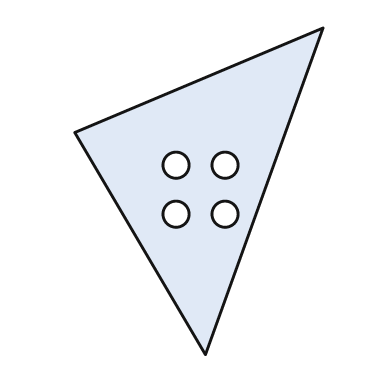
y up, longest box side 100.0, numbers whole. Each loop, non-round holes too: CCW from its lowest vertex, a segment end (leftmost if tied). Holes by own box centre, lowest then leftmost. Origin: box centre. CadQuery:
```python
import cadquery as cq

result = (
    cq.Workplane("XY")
    .moveTo(2.0, -50.0)
    .lineTo(38.0, 50.0)
    .lineTo(-38.0, 18.0)
    .close()
    .moveTo(-7.0, -7.0)
    .circle(4.0)
    .moveTo(8.0, -7.0)
    .circle(4.0)
    .moveTo(-7.0, 8.0)
    .circle(4.0)
    .moveTo(8.0, 8.0)
    .circle(4.0)
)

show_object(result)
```